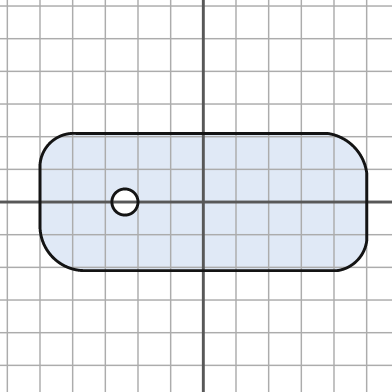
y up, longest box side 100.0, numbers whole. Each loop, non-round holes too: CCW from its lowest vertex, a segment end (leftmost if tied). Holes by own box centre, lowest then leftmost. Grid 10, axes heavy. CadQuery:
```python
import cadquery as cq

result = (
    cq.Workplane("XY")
    .moveTo(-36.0, -21.0)
    .lineTo(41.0, -21.0)
    .threePointArc((47.0, -18.0), (50.0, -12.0))
    .lineTo(50.0, 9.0)
    .threePointArc((46.0, 17.0), (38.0, 21.0))
    .lineTo(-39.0, 21.0)
    .threePointArc((-47.0, 18.0), (-50.0, 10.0))
    .lineTo(-50.0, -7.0)
    .threePointArc((-46.0, -17.0), (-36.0, -21.0))
    .close()
    .moveTo(-24.0, 0.0)
    .circle(4.0)
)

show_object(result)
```